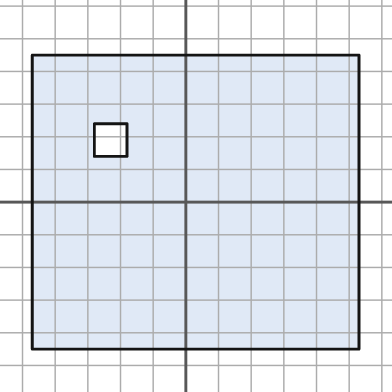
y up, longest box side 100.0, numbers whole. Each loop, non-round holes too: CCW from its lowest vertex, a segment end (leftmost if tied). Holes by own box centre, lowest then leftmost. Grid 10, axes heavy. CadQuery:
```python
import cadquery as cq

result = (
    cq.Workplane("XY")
    .moveTo(-47.0, -45.0)
    .lineTo(53.0, -45.0)
    .lineTo(53.0, 45.0)
    .lineTo(-47.0, 45.0)
    .close()
    .moveTo(-28.0, 14.0)
    .lineTo(-18.0, 14.0)
    .lineTo(-18.0, 24.0)
    .lineTo(-28.0, 24.0)
    .close()
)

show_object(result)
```